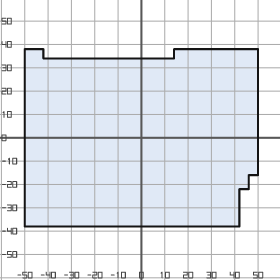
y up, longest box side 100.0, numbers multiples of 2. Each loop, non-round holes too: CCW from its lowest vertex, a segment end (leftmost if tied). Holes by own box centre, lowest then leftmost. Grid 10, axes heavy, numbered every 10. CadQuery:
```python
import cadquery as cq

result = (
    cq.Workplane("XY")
    .moveTo(-50.0, -38.0)
    .lineTo(42.0, -38.0)
    .lineTo(42.0, -22.0)
    .lineTo(46.0, -22.0)
    .lineTo(46.0, -16.0)
    .lineTo(50.0, -16.0)
    .lineTo(50.0, 38.0)
    .lineTo(14.0, 38.0)
    .lineTo(14.0, 34.0)
    .lineTo(-42.0, 34.0)
    .lineTo(-42.0, 38.0)
    .lineTo(-50.0, 38.0)
    .close()
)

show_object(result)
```